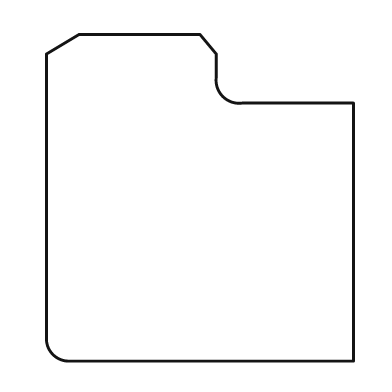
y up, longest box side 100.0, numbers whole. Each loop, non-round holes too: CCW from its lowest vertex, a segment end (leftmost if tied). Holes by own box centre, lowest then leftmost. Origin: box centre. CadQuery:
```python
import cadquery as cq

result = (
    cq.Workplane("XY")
    .moveTo(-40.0, -50.0)
    .lineTo(47.0, -50.0)
    .lineTo(47.0, 29.0)
    .lineTo(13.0, 29.0)
    .threePointArc((7.0, 31.0), (5.0, 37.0))
    .lineTo(5.0, 44.0)
    .lineTo(0.0, 50.0)
    .lineTo(-37.0, 50.0)
    .lineTo(-47.0, 44.0)
    .lineTo(-47.0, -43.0)
    .threePointArc((-45.0, -48.0), (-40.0, -50.0))
    .close()
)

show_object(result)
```